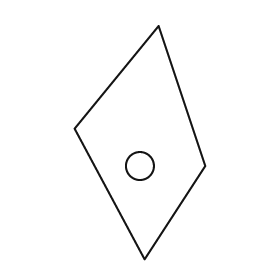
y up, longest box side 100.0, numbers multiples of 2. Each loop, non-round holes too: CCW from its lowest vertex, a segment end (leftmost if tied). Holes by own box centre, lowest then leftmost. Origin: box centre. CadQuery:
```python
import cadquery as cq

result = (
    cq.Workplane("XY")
    .moveTo(2.0, -50.0)
    .lineTo(28.0, -10.0)
    .lineTo(8.0, 50.0)
    .lineTo(-28.0, 6.0)
    .close()
    .moveTo(0.0, -10.0)
    .circle(6.0)
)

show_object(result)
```